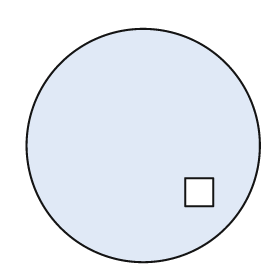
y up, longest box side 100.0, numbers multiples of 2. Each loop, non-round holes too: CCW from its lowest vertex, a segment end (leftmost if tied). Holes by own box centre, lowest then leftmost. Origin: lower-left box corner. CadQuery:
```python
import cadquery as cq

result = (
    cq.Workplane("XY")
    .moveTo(50.0, 50.0)
    .circle(50.0)
    .moveTo(68.0, 24.0)
    .lineTo(80.0, 24.0)
    .lineTo(80.0, 36.0)
    .lineTo(68.0, 36.0)
    .close()
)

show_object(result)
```